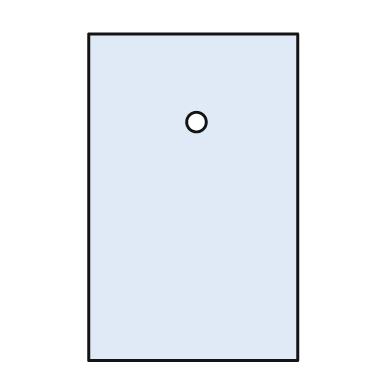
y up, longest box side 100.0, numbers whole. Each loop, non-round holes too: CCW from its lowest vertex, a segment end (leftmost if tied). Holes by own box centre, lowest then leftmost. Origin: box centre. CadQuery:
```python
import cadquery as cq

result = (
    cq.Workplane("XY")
    .moveTo(-32.0, -50.0)
    .lineTo(32.0, -50.0)
    .lineTo(32.0, 50.0)
    .lineTo(-32.0, 50.0)
    .close()
    .moveTo(1.0, 23.0)
    .circle(3.0)
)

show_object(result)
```